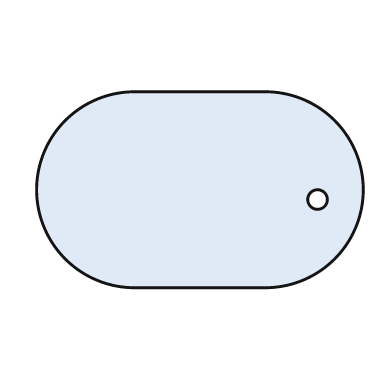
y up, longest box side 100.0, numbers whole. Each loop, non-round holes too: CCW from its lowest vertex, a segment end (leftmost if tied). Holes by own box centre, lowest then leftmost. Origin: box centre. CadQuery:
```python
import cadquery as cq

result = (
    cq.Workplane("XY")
    .moveTo(-20.0, -30.0)
    .lineTo(20.0, -30.0)
    .threePointArc((50.0, 0.0), (20.0, 30.0))
    .lineTo(-20.0, 30.0)
    .threePointArc((-50.0, 0.0), (-20.0, -30.0))
    .close()
    .moveTo(36.0, -3.0)
    .circle(3.0)
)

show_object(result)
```